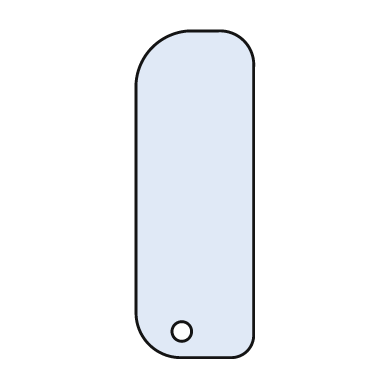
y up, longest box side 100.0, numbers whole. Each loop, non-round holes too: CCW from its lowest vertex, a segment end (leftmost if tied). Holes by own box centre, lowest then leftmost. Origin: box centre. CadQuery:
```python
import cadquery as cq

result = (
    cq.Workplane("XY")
    .moveTo(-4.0, -50.0)
    .lineTo(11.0, -50.0)
    .threePointArc((16.0, -48.0), (18.0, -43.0))
    .lineTo(18.0, 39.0)
    .threePointArc((15.0, 47.0), (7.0, 50.0))
    .lineTo(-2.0, 50.0)
    .threePointArc((-13.0, 45.0), (-18.0, 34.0))
    .lineTo(-18.0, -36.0)
    .threePointArc((-14.0, -46.0), (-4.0, -50.0))
    .close()
    .moveTo(-4.0, -42.0)
    .circle(3.0)
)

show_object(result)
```